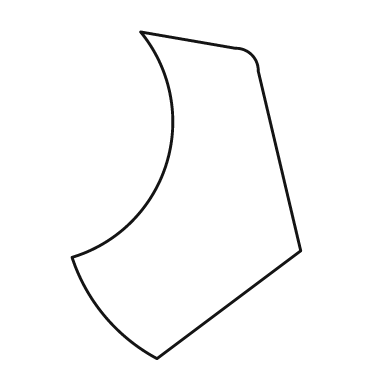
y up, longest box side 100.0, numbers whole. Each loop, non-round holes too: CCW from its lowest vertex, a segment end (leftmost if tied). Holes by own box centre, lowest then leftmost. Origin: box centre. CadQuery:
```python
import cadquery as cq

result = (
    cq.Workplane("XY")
    .moveTo(-9.0, -50.0)
    .lineTo(35.0, -17.0)
    .lineTo(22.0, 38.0)
    .threePointArc((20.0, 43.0), (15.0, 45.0))
    .lineTo(-14.0, 50.0)
    .threePointArc((-6.0, 10.0), (-35.0, -19.0))
    .threePointArc((-25.0, -37.0), (-9.0, -50.0))
    .close()
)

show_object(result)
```